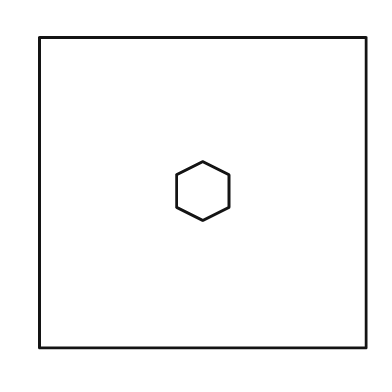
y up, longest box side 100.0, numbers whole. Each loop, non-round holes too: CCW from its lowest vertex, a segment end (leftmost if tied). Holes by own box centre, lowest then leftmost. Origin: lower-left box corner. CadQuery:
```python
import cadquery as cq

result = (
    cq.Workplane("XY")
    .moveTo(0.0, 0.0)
    .lineTo(100.0, 0.0)
    .lineTo(100.0, 95.0)
    .lineTo(0.0, 95.0)
    .close()
    .moveTo(50.0, 39.0)
    .lineTo(58.0, 43.0)
    .lineTo(58.0, 53.0)
    .lineTo(50.0, 57.0)
    .lineTo(42.0, 53.0)
    .lineTo(42.0, 43.0)
    .close()
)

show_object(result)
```